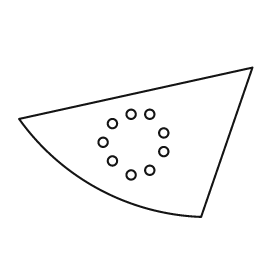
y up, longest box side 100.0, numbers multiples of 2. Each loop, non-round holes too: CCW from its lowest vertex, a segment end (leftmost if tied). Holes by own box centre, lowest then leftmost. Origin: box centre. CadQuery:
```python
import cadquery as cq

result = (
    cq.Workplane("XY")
    .moveTo(28.0, -32.0)
    .lineTo(50.0, 32.0)
    .lineTo(-50.0, 10.0)
    .threePointArc((-16.0, -20.0), (28.0, -32.0))
    .close()
    .moveTo(-2.0, -14.0)
    .circle(2.0)
    .moveTo(6.0, -12.0)
    .circle(2.0)
    .moveTo(-10.0, -8.0)
    .circle(2.0)
    .moveTo(12.0, -4.0)
    .circle(2.0)
    .moveTo(-14.0, 0.0)
    .circle(2.0)
    .moveTo(12.0, 4.0)
    .circle(2.0)
    .moveTo(-10.0, 8.0)
    .circle(2.0)
    .moveTo(-2.0, 12.0)
    .circle(2.0)
    .moveTo(6.0, 12.0)
    .circle(2.0)
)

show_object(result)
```